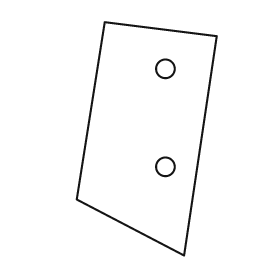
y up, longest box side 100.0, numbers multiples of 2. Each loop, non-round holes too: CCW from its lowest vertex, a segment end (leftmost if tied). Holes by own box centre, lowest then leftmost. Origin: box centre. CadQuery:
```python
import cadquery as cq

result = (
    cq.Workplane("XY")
    .moveTo(16.0, -50.0)
    .lineTo(30.0, 44.0)
    .lineTo(-18.0, 50.0)
    .lineTo(-30.0, -26.0)
    .close()
    .moveTo(8.0, -12.0)
    .circle(4.0)
    .moveTo(8.0, 30.0)
    .circle(4.0)
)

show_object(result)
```